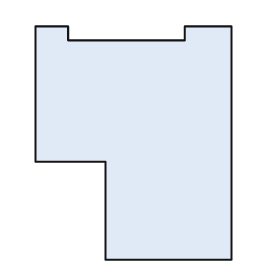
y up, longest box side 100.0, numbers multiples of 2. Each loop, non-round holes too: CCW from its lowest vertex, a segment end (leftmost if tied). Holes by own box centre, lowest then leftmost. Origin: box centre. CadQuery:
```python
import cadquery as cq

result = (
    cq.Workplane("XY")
    .moveTo(-12.0, -50.0)
    .lineTo(42.0, -50.0)
    .lineTo(42.0, 50.0)
    .lineTo(22.0, 50.0)
    .lineTo(22.0, 44.0)
    .lineTo(-28.0, 44.0)
    .lineTo(-28.0, 50.0)
    .lineTo(-42.0, 50.0)
    .lineTo(-42.0, -8.0)
    .lineTo(-12.0, -8.0)
    .close()
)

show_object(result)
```